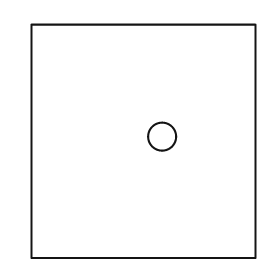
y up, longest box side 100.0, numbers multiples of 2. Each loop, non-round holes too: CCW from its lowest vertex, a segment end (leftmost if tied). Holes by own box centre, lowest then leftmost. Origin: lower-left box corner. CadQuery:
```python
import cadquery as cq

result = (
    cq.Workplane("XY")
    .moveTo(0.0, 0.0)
    .lineTo(96.0, 0.0)
    .lineTo(96.0, 100.0)
    .lineTo(0.0, 100.0)
    .close()
    .moveTo(56.0, 52.0)
    .circle(6.0)
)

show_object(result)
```